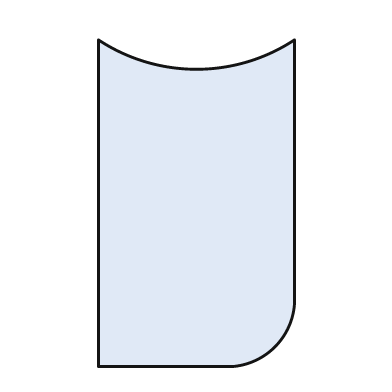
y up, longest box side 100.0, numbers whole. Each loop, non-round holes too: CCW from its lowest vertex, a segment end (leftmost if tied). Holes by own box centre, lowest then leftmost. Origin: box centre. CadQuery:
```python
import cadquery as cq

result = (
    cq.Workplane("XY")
    .moveTo(-30.0, -50.0)
    .lineTo(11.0, -50.0)
    .threePointArc((24.0, -44.0), (30.0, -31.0))
    .lineTo(30.0, 50.0)
    .threePointArc((0.0, 41.0), (-30.0, 50.0))
    .close()
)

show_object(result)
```